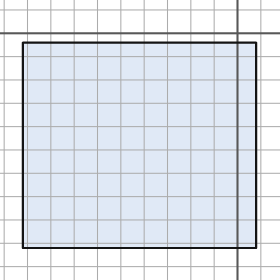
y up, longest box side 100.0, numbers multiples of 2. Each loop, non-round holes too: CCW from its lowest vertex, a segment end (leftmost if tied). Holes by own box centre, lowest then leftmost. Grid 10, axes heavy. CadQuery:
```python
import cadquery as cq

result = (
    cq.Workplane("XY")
    .moveTo(-92.0, -92.0)
    .lineTo(8.0, -92.0)
    .lineTo(8.0, -4.0)
    .lineTo(-92.0, -4.0)
    .close()
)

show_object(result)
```